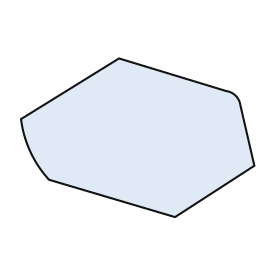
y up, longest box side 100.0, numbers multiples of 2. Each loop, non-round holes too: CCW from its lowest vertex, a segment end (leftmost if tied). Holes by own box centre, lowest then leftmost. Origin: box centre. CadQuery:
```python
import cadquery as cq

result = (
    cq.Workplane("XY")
    .moveTo(16.0, -34.0)
    .lineTo(50.0, -12.0)
    .lineTo(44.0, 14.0)
    .threePointArc((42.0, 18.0), (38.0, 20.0))
    .lineTo(-8.0, 34.0)
    .lineTo(-50.0, 8.0)
    .threePointArc((-46.0, -6.0), (-38.0, -18.0))
    .close()
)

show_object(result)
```